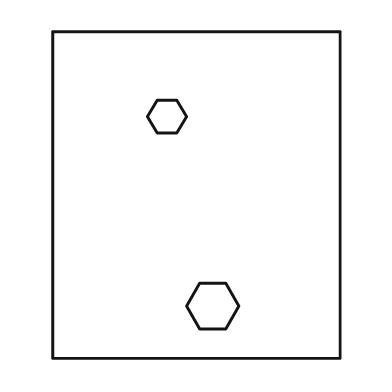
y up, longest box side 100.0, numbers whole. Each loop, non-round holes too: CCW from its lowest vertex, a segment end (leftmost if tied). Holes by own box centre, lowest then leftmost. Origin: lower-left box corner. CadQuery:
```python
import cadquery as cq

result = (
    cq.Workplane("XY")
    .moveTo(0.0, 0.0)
    .lineTo(88.0, 0.0)
    .lineTo(88.0, 100.0)
    .lineTo(0.0, 100.0)
    .close()
    .moveTo(45.0, 9.0)
    .lineTo(53.0, 9.0)
    .lineTo(57.0, 16.0)
    .lineTo(53.0, 23.0)
    .lineTo(45.0, 23.0)
    .lineTo(41.0, 16.0)
    .close()
    .moveTo(32.0, 69.0)
    .lineTo(38.0, 69.0)
    .lineTo(41.0, 74.0)
    .lineTo(38.0, 79.0)
    .lineTo(32.0, 79.0)
    .lineTo(29.0, 74.0)
    .close()
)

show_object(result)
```